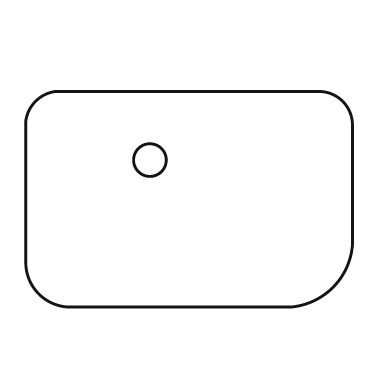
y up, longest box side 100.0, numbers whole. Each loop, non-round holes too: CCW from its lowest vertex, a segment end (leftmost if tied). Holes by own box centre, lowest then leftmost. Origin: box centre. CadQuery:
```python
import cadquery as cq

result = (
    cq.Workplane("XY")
    .moveTo(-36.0, -33.0)
    .lineTo(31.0, -33.0)
    .threePointArc((44.0, -27.0), (50.0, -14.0))
    .lineTo(50.0, 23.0)
    .threePointArc((47.0, 30.0), (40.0, 33.0))
    .lineTo(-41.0, 33.0)
    .threePointArc((-47.0, 30.0), (-50.0, 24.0))
    .lineTo(-50.0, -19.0)
    .threePointArc((-46.0, -29.0), (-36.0, -33.0))
    .close()
    .moveTo(-12.0, 12.0)
    .circle(5.0)
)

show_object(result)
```